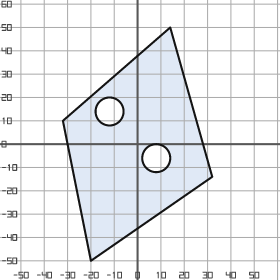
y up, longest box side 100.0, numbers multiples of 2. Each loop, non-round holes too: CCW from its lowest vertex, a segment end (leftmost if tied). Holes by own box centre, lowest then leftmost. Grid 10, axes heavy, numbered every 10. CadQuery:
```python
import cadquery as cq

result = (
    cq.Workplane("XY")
    .moveTo(-20.0, -50.0)
    .lineTo(32.0, -14.0)
    .lineTo(14.0, 50.0)
    .lineTo(-32.0, 10.0)
    .close()
    .moveTo(8.0, -6.0)
    .circle(6.0)
    .moveTo(-12.0, 14.0)
    .circle(6.0)
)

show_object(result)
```